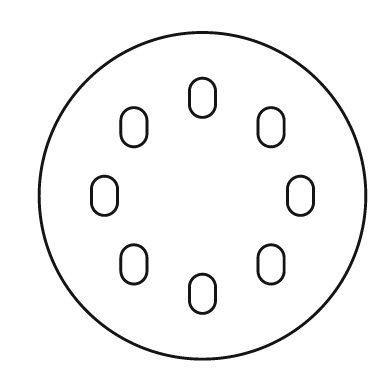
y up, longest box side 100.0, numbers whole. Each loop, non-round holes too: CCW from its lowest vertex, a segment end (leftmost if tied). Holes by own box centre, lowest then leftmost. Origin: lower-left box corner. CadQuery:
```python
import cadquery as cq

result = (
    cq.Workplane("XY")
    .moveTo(50.0, 50.0)
    .circle(50.0)
    .moveTo(46.0, 18.0)
    .threePointArc((50.0, 14.0), (54.0, 18.0))
    .lineTo(54.0, 22.0)
    .threePointArc((50.0, 26.0), (46.0, 22.0))
    .close()
    .moveTo(25.0, 27.0)
    .threePointArc((29.0, 23.0), (33.0, 27.0))
    .lineTo(33.0, 31.0)
    .threePointArc((29.0, 35.0), (25.0, 31.0))
    .close()
    .moveTo(67.0, 27.0)
    .threePointArc((71.0, 23.0), (75.0, 27.0))
    .lineTo(75.0, 31.0)
    .threePointArc((71.0, 35.0), (67.0, 31.0))
    .close()
    .moveTo(16.0, 48.0)
    .threePointArc((20.0, 44.0), (24.0, 48.0))
    .lineTo(24.0, 52.0)
    .threePointArc((20.0, 56.0), (16.0, 52.0))
    .close()
    .moveTo(76.0, 48.0)
    .threePointArc((80.0, 44.0), (84.0, 48.0))
    .lineTo(84.0, 52.0)
    .threePointArc((80.0, 56.0), (76.0, 52.0))
    .close()
    .moveTo(25.0, 69.0)
    .threePointArc((29.0, 65.0), (33.0, 69.0))
    .lineTo(33.0, 73.0)
    .threePointArc((29.0, 77.0), (25.0, 73.0))
    .close()
    .moveTo(67.0, 69.0)
    .threePointArc((71.0, 65.0), (75.0, 69.0))
    .lineTo(75.0, 73.0)
    .threePointArc((71.0, 77.0), (67.0, 73.0))
    .close()
    .moveTo(46.0, 78.0)
    .threePointArc((50.0, 74.0), (54.0, 78.0))
    .lineTo(54.0, 82.0)
    .threePointArc((50.0, 86.0), (46.0, 82.0))
    .close()
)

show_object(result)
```